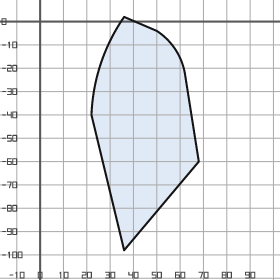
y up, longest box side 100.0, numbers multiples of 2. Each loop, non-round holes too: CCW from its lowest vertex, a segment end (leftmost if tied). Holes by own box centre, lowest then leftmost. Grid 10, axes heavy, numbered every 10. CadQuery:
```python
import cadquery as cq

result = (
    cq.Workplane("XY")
    .moveTo(36.0, -98.0)
    .lineTo(68.0, -60.0)
    .lineTo(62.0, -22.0)
    .threePointArc((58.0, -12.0), (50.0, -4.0))
    .lineTo(36.0, 2.0)
    .threePointArc((26.0, -18.0), (22.0, -40.0))
    .close()
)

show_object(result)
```